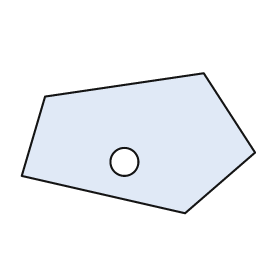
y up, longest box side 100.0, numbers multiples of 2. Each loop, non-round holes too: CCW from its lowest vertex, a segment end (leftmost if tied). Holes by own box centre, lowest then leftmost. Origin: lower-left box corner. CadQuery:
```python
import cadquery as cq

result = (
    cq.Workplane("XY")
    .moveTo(70.0, 0.0)
    .lineTo(100.0, 26.0)
    .lineTo(78.0, 60.0)
    .lineTo(10.0, 50.0)
    .lineTo(0.0, 16.0)
    .close()
    .moveTo(44.0, 22.0)
    .circle(6.0)
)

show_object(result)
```